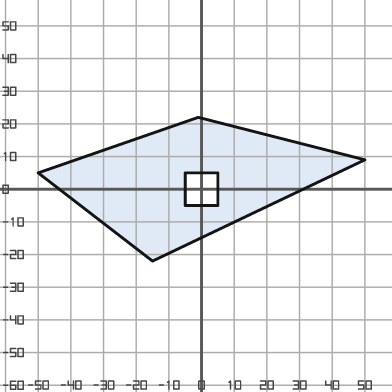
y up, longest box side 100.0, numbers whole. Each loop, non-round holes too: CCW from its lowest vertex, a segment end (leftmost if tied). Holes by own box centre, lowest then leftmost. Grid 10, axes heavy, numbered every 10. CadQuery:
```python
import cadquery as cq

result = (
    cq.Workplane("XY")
    .moveTo(-15.0, -22.0)
    .lineTo(50.0, 9.0)
    .lineTo(-1.0, 22.0)
    .lineTo(-50.0, 5.0)
    .close()
    .moveTo(-5.0, -5.0)
    .lineTo(5.0, -5.0)
    .lineTo(5.0, 5.0)
    .lineTo(-5.0, 5.0)
    .close()
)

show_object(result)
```